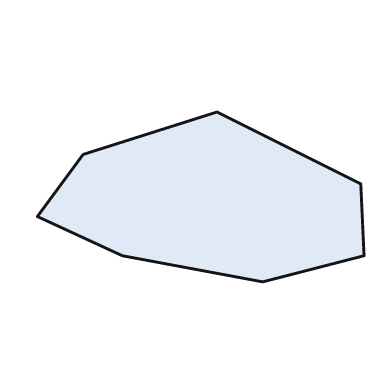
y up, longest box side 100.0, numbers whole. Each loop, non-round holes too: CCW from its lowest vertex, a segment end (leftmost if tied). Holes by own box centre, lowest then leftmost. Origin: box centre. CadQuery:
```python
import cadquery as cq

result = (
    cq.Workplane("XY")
    .moveTo(19.0, -26.0)
    .lineTo(50.0, -18.0)
    .lineTo(49.0, 4.0)
    .lineTo(5.0, 26.0)
    .lineTo(-36.0, 13.0)
    .lineTo(-50.0, -6.0)
    .lineTo(-24.0, -18.0)
    .close()
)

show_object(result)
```